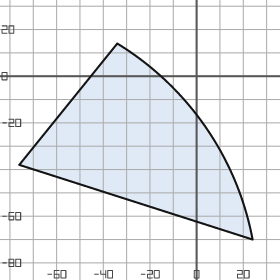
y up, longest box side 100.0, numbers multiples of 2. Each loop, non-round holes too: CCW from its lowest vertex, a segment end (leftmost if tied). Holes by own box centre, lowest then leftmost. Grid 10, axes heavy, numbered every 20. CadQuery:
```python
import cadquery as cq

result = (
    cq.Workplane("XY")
    .moveTo(24.0, -70.0)
    .threePointArc((4.0, -22.0), (-34.0, 14.0))
    .lineTo(-76.0, -38.0)
    .close()
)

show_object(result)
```